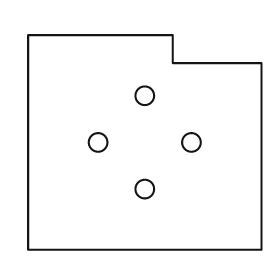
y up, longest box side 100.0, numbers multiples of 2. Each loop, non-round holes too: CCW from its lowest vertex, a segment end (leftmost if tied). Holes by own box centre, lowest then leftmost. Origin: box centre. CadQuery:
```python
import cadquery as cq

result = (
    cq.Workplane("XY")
    .moveTo(-50.0, -46.0)
    .lineTo(50.0, -46.0)
    .lineTo(50.0, 34.0)
    .lineTo(12.0, 34.0)
    .lineTo(12.0, 46.0)
    .lineTo(-50.0, 46.0)
    .close()
    .moveTo(0.0, -20.0)
    .circle(4.0)
    .moveTo(-20.0, 0.0)
    .circle(4.0)
    .moveTo(20.0, 0.0)
    .circle(4.0)
    .moveTo(0.0, 20.0)
    .circle(4.0)
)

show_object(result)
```